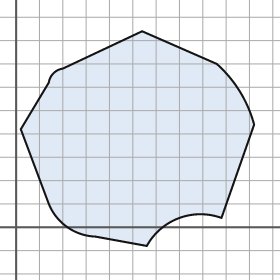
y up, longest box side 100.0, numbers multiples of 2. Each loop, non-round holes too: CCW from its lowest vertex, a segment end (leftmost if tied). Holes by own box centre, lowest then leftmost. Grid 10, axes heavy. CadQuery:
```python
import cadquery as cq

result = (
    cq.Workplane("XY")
    .moveTo(56.0, -8.0)
    .threePointArc((70.0, 4.0), (88.0, 4.0))
    .lineTo(102.0, 44.0)
    .threePointArc((96.0, 58.0), (86.0, 70.0))
    .lineTo(54.0, 84.0)
    .lineTo(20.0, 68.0)
    .threePointArc((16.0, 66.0), (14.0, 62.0))
    .lineTo(2.0, 42.0)
    .lineTo(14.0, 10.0)
    .threePointArc((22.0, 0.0), (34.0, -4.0))
    .close()
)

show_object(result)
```